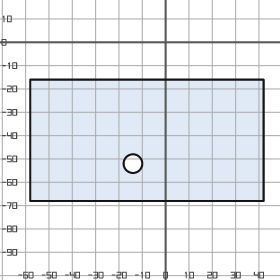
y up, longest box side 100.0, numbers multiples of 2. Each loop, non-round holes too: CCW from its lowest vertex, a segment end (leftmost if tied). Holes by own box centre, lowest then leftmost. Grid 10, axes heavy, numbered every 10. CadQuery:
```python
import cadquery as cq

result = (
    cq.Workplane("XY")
    .moveTo(-58.0, -68.0)
    .lineTo(42.0, -68.0)
    .lineTo(42.0, -16.0)
    .lineTo(-58.0, -16.0)
    .close()
    .moveTo(-14.0, -52.0)
    .circle(4.0)
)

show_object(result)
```